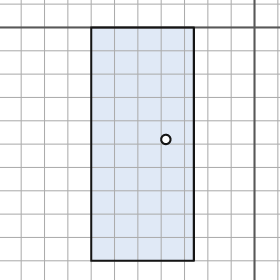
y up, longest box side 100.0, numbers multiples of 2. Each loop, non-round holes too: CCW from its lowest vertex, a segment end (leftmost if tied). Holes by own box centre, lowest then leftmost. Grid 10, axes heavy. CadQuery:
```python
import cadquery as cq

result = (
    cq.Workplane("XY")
    .moveTo(-70.0, -100.0)
    .lineTo(-26.0, -100.0)
    .lineTo(-26.0, 0.0)
    .lineTo(-70.0, 0.0)
    .close()
    .moveTo(-38.0, -48.0)
    .circle(2.0)
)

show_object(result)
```